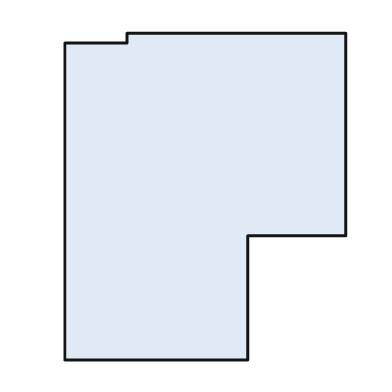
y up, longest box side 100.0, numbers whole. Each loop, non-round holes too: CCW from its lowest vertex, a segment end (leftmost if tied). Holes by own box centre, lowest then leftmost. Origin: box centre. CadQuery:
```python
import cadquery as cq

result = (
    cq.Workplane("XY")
    .moveTo(-43.0, -50.0)
    .lineTo(13.0, -50.0)
    .lineTo(13.0, -12.0)
    .lineTo(43.0, -12.0)
    .lineTo(43.0, 50.0)
    .lineTo(-24.0, 50.0)
    .lineTo(-24.0, 47.0)
    .lineTo(-43.0, 47.0)
    .close()
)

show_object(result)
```